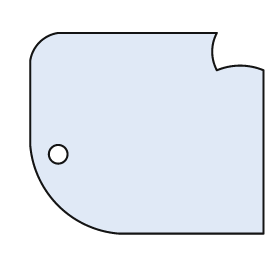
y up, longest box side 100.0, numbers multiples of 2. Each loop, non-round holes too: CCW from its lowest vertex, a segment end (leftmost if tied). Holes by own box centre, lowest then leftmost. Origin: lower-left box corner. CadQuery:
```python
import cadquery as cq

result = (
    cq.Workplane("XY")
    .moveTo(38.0, 0.0)
    .lineTo(100.0, 0.0)
    .lineTo(100.0, 70.0)
    .threePointArc((90.0, 72.0), (80.0, 70.0))
    .threePointArc((78.0, 78.0), (80.0, 86.0))
    .lineTo(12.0, 86.0)
    .threePointArc((4.0, 82.0), (0.0, 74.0))
    .lineTo(0.0, 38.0)
    .threePointArc((12.0, 12.0), (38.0, 0.0))
    .close()
    .moveTo(12.0, 34.0)
    .circle(4.0)
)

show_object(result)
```